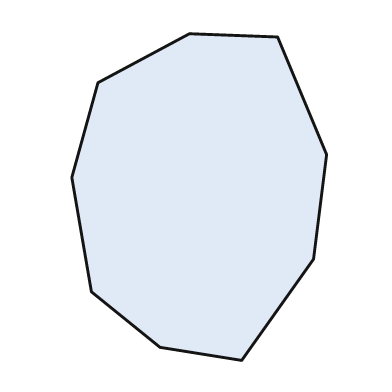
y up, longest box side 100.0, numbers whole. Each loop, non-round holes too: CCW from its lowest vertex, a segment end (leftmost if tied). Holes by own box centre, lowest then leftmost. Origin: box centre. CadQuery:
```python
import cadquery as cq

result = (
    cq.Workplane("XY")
    .moveTo(13.0, -50.0)
    .lineTo(35.0, -19.0)
    .lineTo(39.0, 13.0)
    .lineTo(24.0, 49.0)
    .lineTo(-3.0, 50.0)
    .lineTo(-31.0, 35.0)
    .lineTo(-39.0, 6.0)
    .lineTo(-33.0, -29.0)
    .lineTo(-12.0, -46.0)
    .close()
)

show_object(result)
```